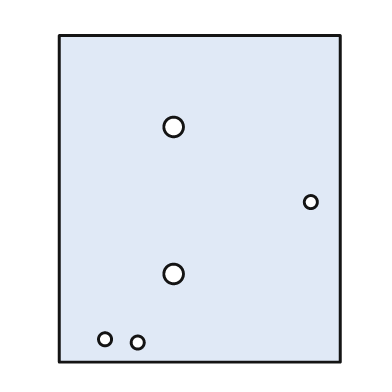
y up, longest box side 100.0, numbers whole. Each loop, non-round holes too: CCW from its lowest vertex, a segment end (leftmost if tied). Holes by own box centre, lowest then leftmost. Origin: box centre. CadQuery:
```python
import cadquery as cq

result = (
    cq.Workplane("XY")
    .moveTo(-43.0, -50.0)
    .lineTo(43.0, -50.0)
    .lineTo(43.0, 50.0)
    .lineTo(-43.0, 50.0)
    .close()
    .moveTo(-19.0, -44.0)
    .circle(2.0)
    .moveTo(-29.0, -43.0)
    .circle(2.0)
    .moveTo(-8.0, -23.0)
    .circle(3.0)
    .moveTo(34.0, -1.0)
    .circle(2.0)
    .moveTo(-8.0, 22.0)
    .circle(3.0)
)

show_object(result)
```